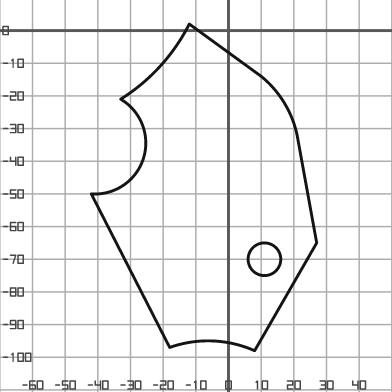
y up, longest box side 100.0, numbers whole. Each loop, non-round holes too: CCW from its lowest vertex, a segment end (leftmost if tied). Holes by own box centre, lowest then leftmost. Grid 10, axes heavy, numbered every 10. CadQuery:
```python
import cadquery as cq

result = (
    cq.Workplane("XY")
    .moveTo(8.0, -98.0)
    .lineTo(27.0, -65.0)
    .lineTo(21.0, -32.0)
    .threePointArc((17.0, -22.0), (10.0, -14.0))
    .lineTo(-12.0, 2.0)
    .threePointArc((-21.0, -11.0), (-33.0, -21.0))
    .threePointArc((-26.0, -39.0), (-42.0, -50.0))
    .lineTo(-18.0, -97.0)
    .threePointArc((-5.0, -95.0), (8.0, -98.0))
    .close()
    .moveTo(11.0, -70.0)
    .circle(5.0)
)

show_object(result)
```